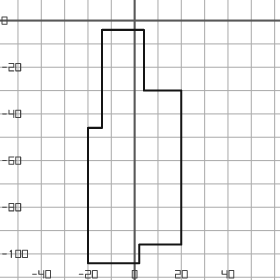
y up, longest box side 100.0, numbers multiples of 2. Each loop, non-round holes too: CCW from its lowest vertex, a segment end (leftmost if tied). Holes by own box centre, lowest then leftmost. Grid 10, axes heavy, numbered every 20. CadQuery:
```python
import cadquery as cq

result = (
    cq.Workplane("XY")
    .moveTo(-20.0, -104.0)
    .lineTo(2.0, -104.0)
    .lineTo(2.0, -96.0)
    .lineTo(20.0, -96.0)
    .lineTo(20.0, -30.0)
    .lineTo(4.0, -30.0)
    .lineTo(4.0, -4.0)
    .lineTo(-14.0, -4.0)
    .lineTo(-14.0, -46.0)
    .lineTo(-20.0, -46.0)
    .close()
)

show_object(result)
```